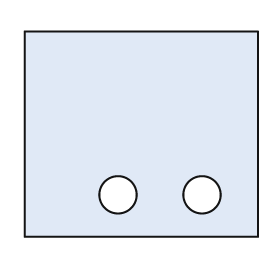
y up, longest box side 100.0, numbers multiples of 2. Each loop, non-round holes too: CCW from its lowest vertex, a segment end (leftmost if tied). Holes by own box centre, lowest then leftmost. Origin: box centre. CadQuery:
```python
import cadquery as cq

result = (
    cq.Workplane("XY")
    .moveTo(-50.0, -44.0)
    .lineTo(50.0, -44.0)
    .lineTo(50.0, 44.0)
    .lineTo(-50.0, 44.0)
    .close()
    .moveTo(-10.0, -26.0)
    .circle(8.0)
    .moveTo(26.0, -26.0)
    .circle(8.0)
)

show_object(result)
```